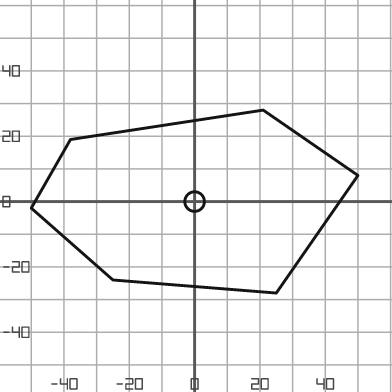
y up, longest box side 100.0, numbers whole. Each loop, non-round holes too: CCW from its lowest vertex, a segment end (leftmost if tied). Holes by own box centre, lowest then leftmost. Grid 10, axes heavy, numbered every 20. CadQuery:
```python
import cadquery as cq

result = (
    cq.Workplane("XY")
    .moveTo(25.0, -28.0)
    .lineTo(50.0, 8.0)
    .lineTo(21.0, 28.0)
    .lineTo(-38.0, 19.0)
    .lineTo(-50.0, -2.0)
    .lineTo(-25.0, -24.0)
    .close()
    .moveTo(0.0, 0.0)
    .circle(3.0)
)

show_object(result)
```